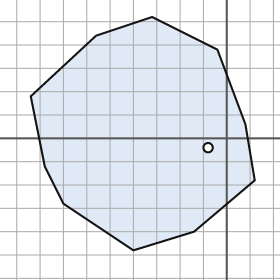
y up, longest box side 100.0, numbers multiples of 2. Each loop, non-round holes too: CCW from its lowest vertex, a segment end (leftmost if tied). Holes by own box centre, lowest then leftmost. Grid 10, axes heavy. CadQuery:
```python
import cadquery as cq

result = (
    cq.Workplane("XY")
    .moveTo(-40.0, -48.0)
    .lineTo(-14.0, -40.0)
    .lineTo(12.0, -18.0)
    .lineTo(8.0, 6.0)
    .lineTo(-4.0, 38.0)
    .lineTo(-32.0, 52.0)
    .lineTo(-56.0, 44.0)
    .lineTo(-84.0, 18.0)
    .lineTo(-78.0, -12.0)
    .lineTo(-70.0, -28.0)
    .close()
    .moveTo(-8.0, -4.0)
    .circle(2.0)
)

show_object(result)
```